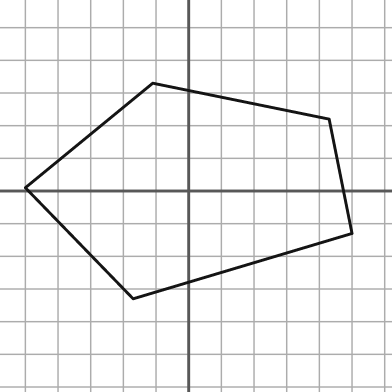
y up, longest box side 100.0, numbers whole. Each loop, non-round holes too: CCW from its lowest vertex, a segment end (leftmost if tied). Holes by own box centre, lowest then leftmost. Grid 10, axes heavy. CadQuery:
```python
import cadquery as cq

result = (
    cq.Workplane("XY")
    .moveTo(-17.0, -33.0)
    .lineTo(50.0, -13.0)
    .lineTo(43.0, 22.0)
    .lineTo(-11.0, 33.0)
    .lineTo(-50.0, 1.0)
    .close()
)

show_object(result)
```